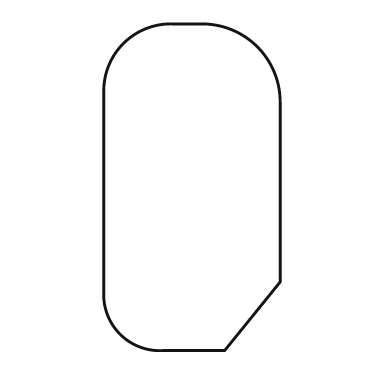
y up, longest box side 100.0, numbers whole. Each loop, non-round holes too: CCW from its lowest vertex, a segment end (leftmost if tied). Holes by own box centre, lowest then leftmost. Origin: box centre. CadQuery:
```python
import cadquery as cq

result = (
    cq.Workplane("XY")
    .moveTo(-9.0, -50.0)
    .lineTo(10.0, -50.0)
    .lineTo(27.0, -29.0)
    .lineTo(27.0, 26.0)
    .threePointArc((20.0, 43.0), (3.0, 50.0))
    .lineTo(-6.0, 50.0)
    .threePointArc((-21.0, 44.0), (-27.0, 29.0))
    .lineTo(-27.0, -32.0)
    .threePointArc((-22.0, -45.0), (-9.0, -50.0))
    .close()
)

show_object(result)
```